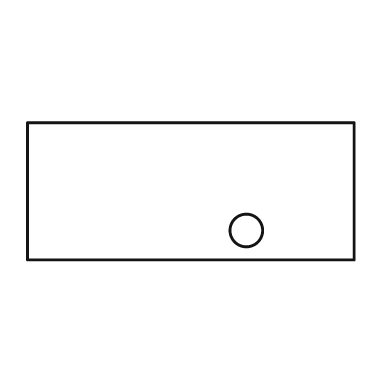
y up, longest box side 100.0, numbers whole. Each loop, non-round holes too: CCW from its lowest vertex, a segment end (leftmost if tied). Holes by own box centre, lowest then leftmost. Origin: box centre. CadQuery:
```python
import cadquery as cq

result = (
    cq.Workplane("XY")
    .moveTo(-50.0, -21.0)
    .lineTo(50.0, -21.0)
    .lineTo(50.0, 21.0)
    .lineTo(-50.0, 21.0)
    .close()
    .moveTo(17.0, -12.0)
    .circle(5.0)
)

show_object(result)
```